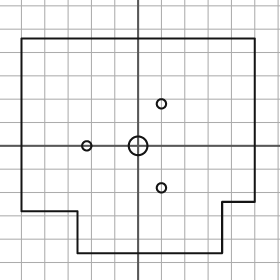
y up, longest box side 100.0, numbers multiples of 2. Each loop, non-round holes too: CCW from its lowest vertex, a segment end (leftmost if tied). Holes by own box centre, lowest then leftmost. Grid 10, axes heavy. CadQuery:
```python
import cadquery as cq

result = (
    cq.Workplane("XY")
    .moveTo(-26.0, -46.0)
    .lineTo(36.0, -46.0)
    .lineTo(36.0, -24.0)
    .lineTo(50.0, -24.0)
    .lineTo(50.0, 46.0)
    .lineTo(-50.0, 46.0)
    .lineTo(-50.0, -28.0)
    .lineTo(-26.0, -28.0)
    .close()
    .moveTo(10.0, -18.0)
    .circle(2.0)
    .moveTo(-22.0, 0.0)
    .circle(2.0)
    .moveTo(0.0, 0.0)
    .circle(4.0)
    .moveTo(10.0, 18.0)
    .circle(2.0)
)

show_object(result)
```